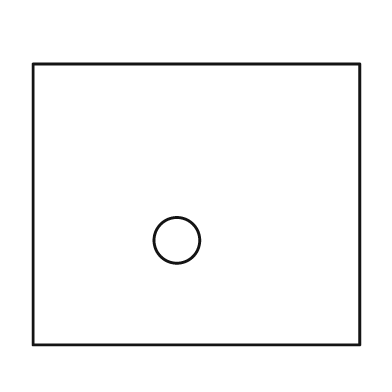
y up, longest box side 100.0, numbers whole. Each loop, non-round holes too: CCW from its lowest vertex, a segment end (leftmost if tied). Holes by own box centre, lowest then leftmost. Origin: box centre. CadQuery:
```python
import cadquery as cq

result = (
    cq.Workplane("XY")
    .moveTo(-50.0, -43.0)
    .lineTo(50.0, -43.0)
    .lineTo(50.0, 43.0)
    .lineTo(-50.0, 43.0)
    .close()
    .moveTo(-6.0, -11.0)
    .circle(7.0)
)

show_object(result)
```